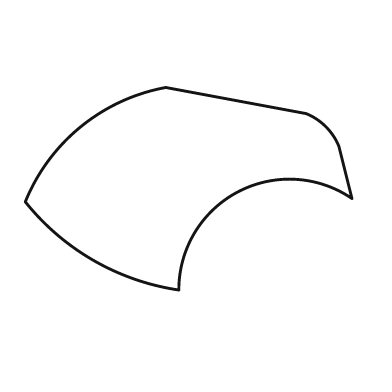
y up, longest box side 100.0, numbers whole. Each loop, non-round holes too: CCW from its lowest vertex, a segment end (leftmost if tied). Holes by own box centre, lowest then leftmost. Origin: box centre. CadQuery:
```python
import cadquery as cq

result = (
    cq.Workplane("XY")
    .moveTo(-3.0, -31.0)
    .threePointArc((15.0, -1.0), (50.0, -3.0))
    .lineTo(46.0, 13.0)
    .threePointArc((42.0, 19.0), (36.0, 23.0))
    .lineTo(-7.0, 31.0)
    .threePointArc((-33.0, 19.0), (-50.0, -4.0))
    .threePointArc((-29.0, -22.0), (-3.0, -31.0))
    .close()
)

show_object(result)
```